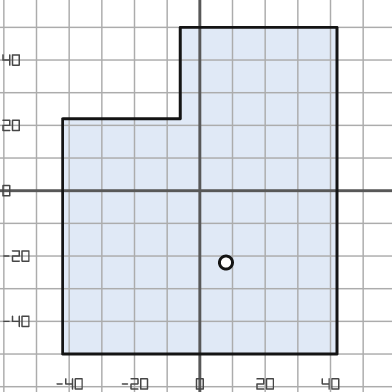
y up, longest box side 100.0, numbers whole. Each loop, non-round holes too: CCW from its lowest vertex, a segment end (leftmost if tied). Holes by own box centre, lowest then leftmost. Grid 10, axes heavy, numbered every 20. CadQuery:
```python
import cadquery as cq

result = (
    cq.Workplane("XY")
    .moveTo(-42.0, -50.0)
    .lineTo(42.0, -50.0)
    .lineTo(42.0, 50.0)
    .lineTo(-6.0, 50.0)
    .lineTo(-6.0, 22.0)
    .lineTo(-42.0, 22.0)
    .close()
    .moveTo(8.0, -22.0)
    .circle(2.0)
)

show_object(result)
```